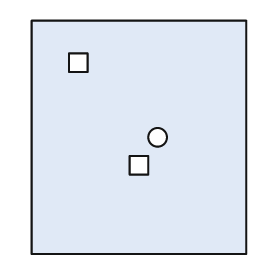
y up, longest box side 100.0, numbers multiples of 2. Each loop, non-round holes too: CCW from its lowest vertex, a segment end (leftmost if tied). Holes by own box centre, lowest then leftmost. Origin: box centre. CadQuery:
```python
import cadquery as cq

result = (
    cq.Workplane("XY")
    .moveTo(-46.0, -50.0)
    .lineTo(46.0, -50.0)
    .lineTo(46.0, 50.0)
    .lineTo(-46.0, 50.0)
    .close()
    .moveTo(-4.0, -16.0)
    .lineTo(4.0, -16.0)
    .lineTo(4.0, -8.0)
    .lineTo(-4.0, -8.0)
    .close()
    .moveTo(8.0, 0.0)
    .circle(4.0)
    .moveTo(-30.0, 28.0)
    .lineTo(-22.0, 28.0)
    .lineTo(-22.0, 36.0)
    .lineTo(-30.0, 36.0)
    .close()
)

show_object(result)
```